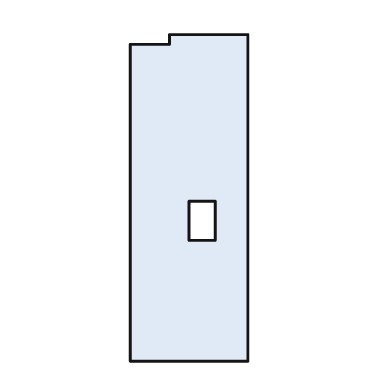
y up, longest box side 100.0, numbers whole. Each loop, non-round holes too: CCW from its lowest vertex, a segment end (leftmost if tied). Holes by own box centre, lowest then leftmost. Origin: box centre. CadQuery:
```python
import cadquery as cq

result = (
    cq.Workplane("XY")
    .moveTo(-18.0, -50.0)
    .lineTo(18.0, -50.0)
    .lineTo(18.0, 50.0)
    .lineTo(-6.0, 50.0)
    .lineTo(-6.0, 47.0)
    .lineTo(-18.0, 47.0)
    .close()
    .moveTo(0.0, -13.0)
    .lineTo(8.0, -13.0)
    .lineTo(8.0, -1.0)
    .lineTo(0.0, -1.0)
    .close()
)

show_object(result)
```